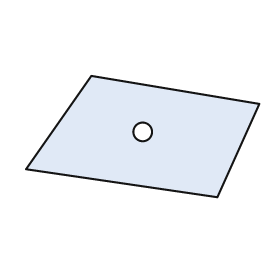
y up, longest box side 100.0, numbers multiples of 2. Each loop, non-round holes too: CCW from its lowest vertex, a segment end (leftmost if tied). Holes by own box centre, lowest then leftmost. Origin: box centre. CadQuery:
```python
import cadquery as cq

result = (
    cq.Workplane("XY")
    .moveTo(32.0, -26.0)
    .lineTo(50.0, 14.0)
    .lineTo(-22.0, 26.0)
    .lineTo(-50.0, -14.0)
    .close()
    .moveTo(0.0, 2.0)
    .circle(4.0)
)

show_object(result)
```